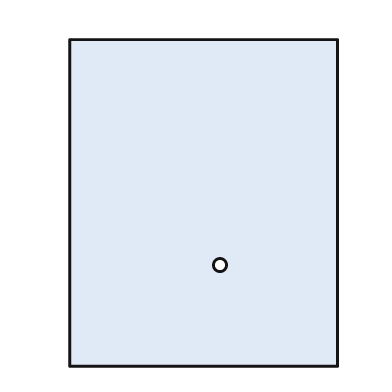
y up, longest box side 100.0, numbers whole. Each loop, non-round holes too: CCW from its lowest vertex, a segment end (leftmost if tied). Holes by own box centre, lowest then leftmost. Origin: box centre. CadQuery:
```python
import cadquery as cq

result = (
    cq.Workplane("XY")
    .moveTo(-41.0, -50.0)
    .lineTo(41.0, -50.0)
    .lineTo(41.0, 50.0)
    .lineTo(-41.0, 50.0)
    .close()
    .moveTo(5.0, -19.0)
    .circle(2.0)
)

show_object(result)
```